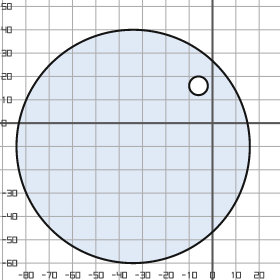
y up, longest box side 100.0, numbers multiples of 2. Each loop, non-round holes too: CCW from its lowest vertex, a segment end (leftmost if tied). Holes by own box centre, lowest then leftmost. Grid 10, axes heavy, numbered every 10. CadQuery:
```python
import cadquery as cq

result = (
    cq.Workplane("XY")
    .moveTo(-34.0, -10.0)
    .circle(50.0)
    .moveTo(-6.0, 16.0)
    .circle(4.0)
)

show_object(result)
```